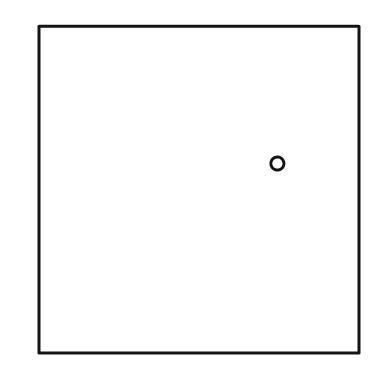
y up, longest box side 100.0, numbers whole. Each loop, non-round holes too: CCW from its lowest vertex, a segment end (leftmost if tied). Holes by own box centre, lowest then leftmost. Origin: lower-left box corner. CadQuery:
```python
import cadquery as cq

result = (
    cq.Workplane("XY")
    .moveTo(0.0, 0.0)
    .lineTo(98.0, 0.0)
    .lineTo(98.0, 100.0)
    .lineTo(0.0, 100.0)
    .close()
    .moveTo(73.0, 58.0)
    .circle(2.0)
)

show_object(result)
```